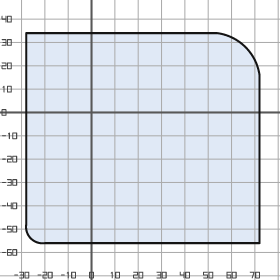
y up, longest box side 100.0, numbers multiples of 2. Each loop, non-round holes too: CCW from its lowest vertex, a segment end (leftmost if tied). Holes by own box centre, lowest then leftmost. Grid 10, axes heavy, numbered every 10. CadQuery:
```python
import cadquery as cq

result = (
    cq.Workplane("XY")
    .moveTo(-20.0, -56.0)
    .lineTo(72.0, -56.0)
    .lineTo(72.0, 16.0)
    .threePointArc((66.0, 28.0), (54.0, 34.0))
    .lineTo(-28.0, 34.0)
    .lineTo(-28.0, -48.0)
    .threePointArc((-26.0, -54.0), (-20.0, -56.0))
    .close()
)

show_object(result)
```